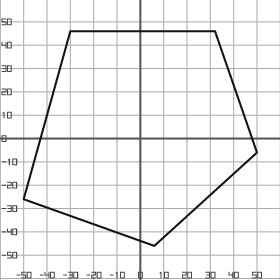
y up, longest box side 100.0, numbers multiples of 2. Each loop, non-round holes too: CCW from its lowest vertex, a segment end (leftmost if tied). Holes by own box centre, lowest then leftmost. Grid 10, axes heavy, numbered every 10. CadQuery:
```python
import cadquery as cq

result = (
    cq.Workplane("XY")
    .moveTo(6.0, -46.0)
    .lineTo(50.0, -6.0)
    .lineTo(32.0, 46.0)
    .lineTo(-30.0, 46.0)
    .lineTo(-50.0, -26.0)
    .close()
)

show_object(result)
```